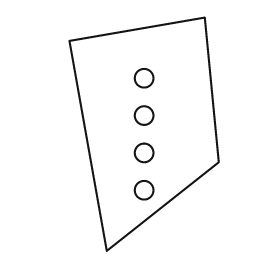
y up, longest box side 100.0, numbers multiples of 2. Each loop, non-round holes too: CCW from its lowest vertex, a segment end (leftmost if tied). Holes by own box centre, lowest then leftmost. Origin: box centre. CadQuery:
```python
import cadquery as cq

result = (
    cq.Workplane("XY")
    .moveTo(-16.0, -50.0)
    .lineTo(32.0, -12.0)
    .lineTo(26.0, 50.0)
    .lineTo(-32.0, 40.0)
    .close()
    .moveTo(0.0, -24.0)
    .circle(4.0)
    .moveTo(0.0, -8.0)
    .circle(4.0)
    .moveTo(0.0, 8.0)
    .circle(4.0)
    .moveTo(0.0, 24.0)
    .circle(4.0)
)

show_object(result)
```